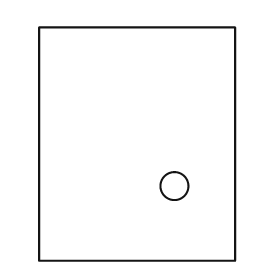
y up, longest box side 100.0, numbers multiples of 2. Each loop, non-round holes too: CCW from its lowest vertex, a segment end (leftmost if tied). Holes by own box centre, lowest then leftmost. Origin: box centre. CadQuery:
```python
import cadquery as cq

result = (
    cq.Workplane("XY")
    .moveTo(-42.0, -50.0)
    .lineTo(42.0, -50.0)
    .lineTo(42.0, 50.0)
    .lineTo(-42.0, 50.0)
    .close()
    .moveTo(16.0, -18.0)
    .circle(6.0)
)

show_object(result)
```